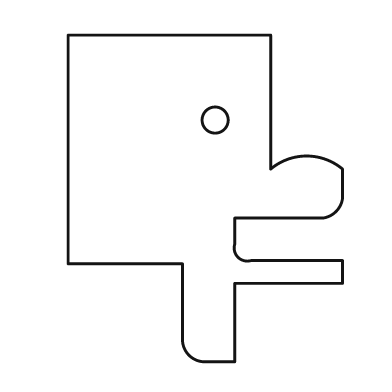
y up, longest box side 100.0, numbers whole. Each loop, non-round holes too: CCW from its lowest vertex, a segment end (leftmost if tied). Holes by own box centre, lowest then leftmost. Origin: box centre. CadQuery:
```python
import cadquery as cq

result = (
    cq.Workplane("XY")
    .moveTo(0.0, -50.0)
    .lineTo(9.0, -50.0)
    .lineTo(9.0, -26.0)
    .lineTo(42.0, -26.0)
    .lineTo(42.0, -19.0)
    .lineTo(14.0, -19.0)
    .threePointArc((10.0, -18.0), (9.0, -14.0))
    .lineTo(9.0, -6.0)
    .lineTo(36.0, -6.0)
    .threePointArc((40.0, -4.0), (42.0, 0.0))
    .lineTo(42.0, 9.0)
    .threePointArc((31.0, 13.0), (20.0, 9.0))
    .lineTo(20.0, 50.0)
    .lineTo(-42.0, 50.0)
    .lineTo(-42.0, -20.0)
    .lineTo(-7.0, -20.0)
    .lineTo(-7.0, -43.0)
    .threePointArc((-5.0, -48.0), (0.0, -50.0))
    .close()
    .moveTo(3.0, 24.0)
    .circle(4.0)
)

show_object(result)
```